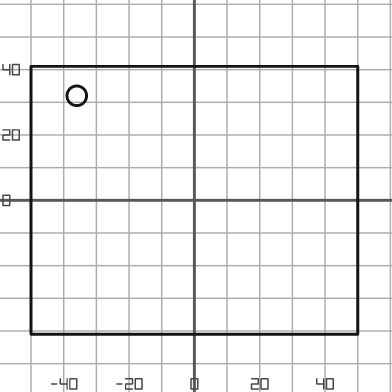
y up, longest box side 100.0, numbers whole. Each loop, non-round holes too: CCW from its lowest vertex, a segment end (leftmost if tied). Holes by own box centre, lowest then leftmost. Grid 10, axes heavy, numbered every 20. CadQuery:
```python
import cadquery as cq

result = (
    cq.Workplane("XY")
    .moveTo(-50.0, -41.0)
    .lineTo(50.0, -41.0)
    .lineTo(50.0, 41.0)
    .lineTo(-50.0, 41.0)
    .close()
    .moveTo(-36.0, 32.0)
    .circle(3.0)
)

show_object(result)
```